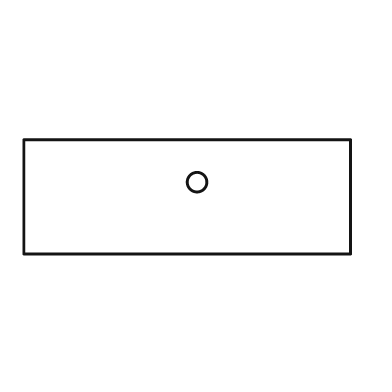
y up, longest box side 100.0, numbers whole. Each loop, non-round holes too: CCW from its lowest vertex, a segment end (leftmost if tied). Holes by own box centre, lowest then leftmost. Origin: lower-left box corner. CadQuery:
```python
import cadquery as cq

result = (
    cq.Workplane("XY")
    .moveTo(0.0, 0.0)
    .lineTo(100.0, 0.0)
    .lineTo(100.0, 35.0)
    .lineTo(0.0, 35.0)
    .close()
    .moveTo(53.0, 22.0)
    .circle(3.0)
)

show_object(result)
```